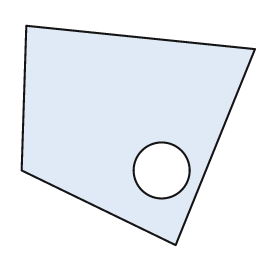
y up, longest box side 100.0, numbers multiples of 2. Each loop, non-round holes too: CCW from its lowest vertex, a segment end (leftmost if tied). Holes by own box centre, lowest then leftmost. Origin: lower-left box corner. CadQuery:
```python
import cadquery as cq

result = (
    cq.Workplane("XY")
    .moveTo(66.0, 0.0)
    .lineTo(100.0, 84.0)
    .lineTo(2.0, 94.0)
    .lineTo(0.0, 32.0)
    .close()
    .moveTo(60.0, 32.0)
    .circle(12.0)
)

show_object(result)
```